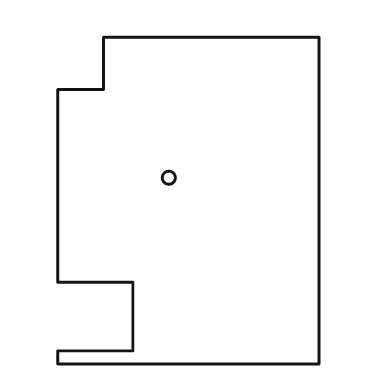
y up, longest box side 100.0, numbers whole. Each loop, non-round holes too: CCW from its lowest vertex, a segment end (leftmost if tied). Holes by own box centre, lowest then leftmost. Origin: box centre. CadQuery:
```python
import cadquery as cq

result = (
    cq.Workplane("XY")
    .moveTo(-40.0, -50.0)
    .lineTo(40.0, -50.0)
    .lineTo(40.0, 50.0)
    .lineTo(-26.0, 50.0)
    .lineTo(-26.0, 34.0)
    .lineTo(-40.0, 34.0)
    .lineTo(-40.0, -25.0)
    .lineTo(-17.0, -25.0)
    .lineTo(-17.0, -46.0)
    .lineTo(-40.0, -46.0)
    .close()
    .moveTo(-6.0, 7.0)
    .circle(2.0)
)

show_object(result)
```